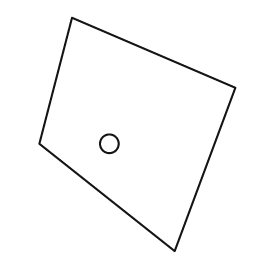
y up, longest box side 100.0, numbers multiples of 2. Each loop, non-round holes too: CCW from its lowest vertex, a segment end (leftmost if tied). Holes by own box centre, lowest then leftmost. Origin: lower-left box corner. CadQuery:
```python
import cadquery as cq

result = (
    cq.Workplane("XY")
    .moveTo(58.0, 0.0)
    .lineTo(84.0, 70.0)
    .lineTo(14.0, 100.0)
    .lineTo(0.0, 46.0)
    .close()
    .moveTo(30.0, 46.0)
    .circle(4.0)
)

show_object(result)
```